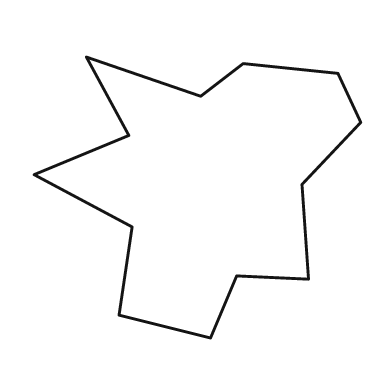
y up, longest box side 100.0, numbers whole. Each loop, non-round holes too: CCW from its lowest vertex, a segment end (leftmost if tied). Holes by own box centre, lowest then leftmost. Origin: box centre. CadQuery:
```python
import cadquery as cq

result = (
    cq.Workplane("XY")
    .moveTo(4.0, -43.0)
    .lineTo(12.0, -24.0)
    .lineTo(34.0, -25.0)
    .lineTo(32.0, 4.0)
    .lineTo(50.0, 23.0)
    .lineTo(43.0, 38.0)
    .lineTo(14.0, 41.0)
    .lineTo(1.0, 31.0)
    .lineTo(-34.0, 43.0)
    .lineTo(-21.0, 19.0)
    .lineTo(-50.0, 7.0)
    .lineTo(-20.0, -9.0)
    .lineTo(-24.0, -36.0)
    .close()
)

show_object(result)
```